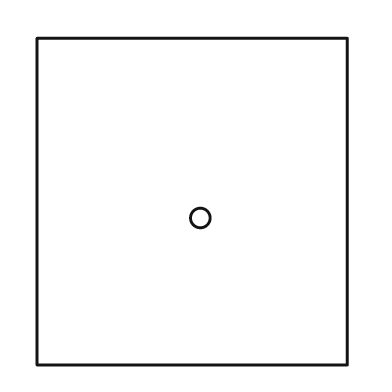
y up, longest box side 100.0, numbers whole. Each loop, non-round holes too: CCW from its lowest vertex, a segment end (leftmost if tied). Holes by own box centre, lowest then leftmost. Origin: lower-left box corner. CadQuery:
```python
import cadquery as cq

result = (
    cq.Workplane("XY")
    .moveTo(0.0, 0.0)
    .lineTo(95.0, 0.0)
    .lineTo(95.0, 100.0)
    .lineTo(0.0, 100.0)
    .close()
    .moveTo(50.0, 45.0)
    .circle(3.0)
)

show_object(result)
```